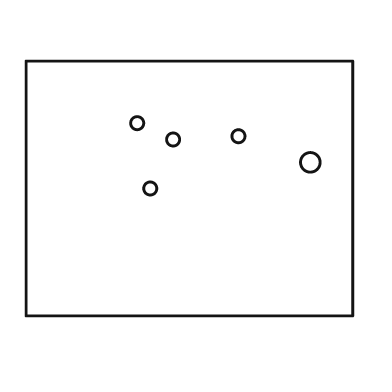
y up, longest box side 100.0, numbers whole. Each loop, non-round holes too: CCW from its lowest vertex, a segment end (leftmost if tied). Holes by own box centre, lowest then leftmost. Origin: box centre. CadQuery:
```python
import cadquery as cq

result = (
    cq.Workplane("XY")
    .moveTo(-50.0, -39.0)
    .lineTo(50.0, -39.0)
    .lineTo(50.0, 39.0)
    .lineTo(-50.0, 39.0)
    .close()
    .moveTo(-12.0, 0.0)
    .circle(2.0)
    .moveTo(37.0, 8.0)
    .circle(3.0)
    .moveTo(-5.0, 15.0)
    .circle(2.0)
    .moveTo(15.0, 16.0)
    .circle(2.0)
    .moveTo(-16.0, 20.0)
    .circle(2.0)
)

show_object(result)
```